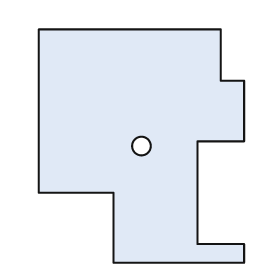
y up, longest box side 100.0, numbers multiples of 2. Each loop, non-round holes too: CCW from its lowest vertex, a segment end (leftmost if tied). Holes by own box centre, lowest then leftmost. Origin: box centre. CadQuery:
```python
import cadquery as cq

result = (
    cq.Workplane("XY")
    .moveTo(-12.0, -50.0)
    .lineTo(44.0, -50.0)
    .lineTo(44.0, -42.0)
    .lineTo(24.0, -42.0)
    .lineTo(24.0, 2.0)
    .lineTo(44.0, 2.0)
    .lineTo(44.0, 28.0)
    .lineTo(34.0, 28.0)
    .lineTo(34.0, 50.0)
    .lineTo(-44.0, 50.0)
    .lineTo(-44.0, -20.0)
    .lineTo(-12.0, -20.0)
    .close()
    .moveTo(0.0, 0.0)
    .circle(4.0)
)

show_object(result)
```